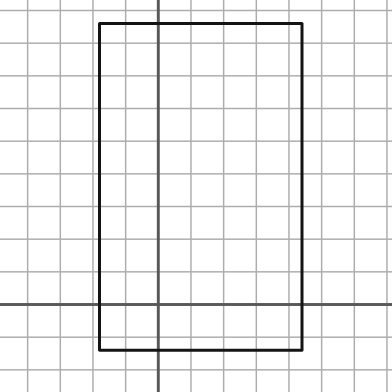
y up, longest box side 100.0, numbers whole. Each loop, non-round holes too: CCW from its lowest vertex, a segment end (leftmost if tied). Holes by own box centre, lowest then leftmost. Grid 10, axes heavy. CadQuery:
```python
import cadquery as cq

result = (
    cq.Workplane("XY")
    .moveTo(-18.0, -14.0)
    .lineTo(44.0, -14.0)
    .lineTo(44.0, 86.0)
    .lineTo(-18.0, 86.0)
    .close()
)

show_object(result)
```